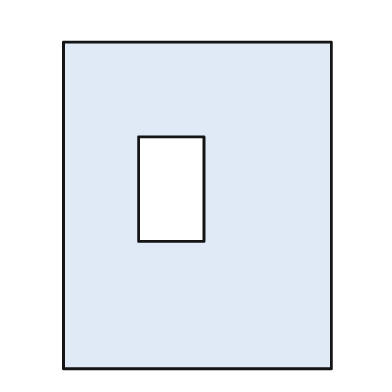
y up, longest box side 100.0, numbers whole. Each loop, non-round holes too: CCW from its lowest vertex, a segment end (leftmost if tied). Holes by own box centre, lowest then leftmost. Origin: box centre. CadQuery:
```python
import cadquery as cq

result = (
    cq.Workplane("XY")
    .moveTo(-41.0, -50.0)
    .lineTo(41.0, -50.0)
    .lineTo(41.0, 50.0)
    .lineTo(-41.0, 50.0)
    .close()
    .moveTo(-18.0, -11.0)
    .lineTo(2.0, -11.0)
    .lineTo(2.0, 21.0)
    .lineTo(-18.0, 21.0)
    .close()
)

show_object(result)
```